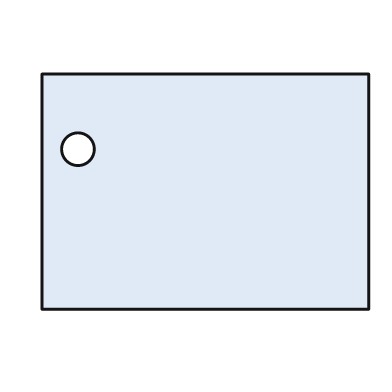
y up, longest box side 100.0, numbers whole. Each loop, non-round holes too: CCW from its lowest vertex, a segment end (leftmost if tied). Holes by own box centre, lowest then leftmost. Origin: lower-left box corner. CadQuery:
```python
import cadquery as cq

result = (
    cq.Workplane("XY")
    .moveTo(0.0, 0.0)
    .lineTo(100.0, 0.0)
    .lineTo(100.0, 72.0)
    .lineTo(0.0, 72.0)
    .close()
    .moveTo(11.0, 49.0)
    .circle(5.0)
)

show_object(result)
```